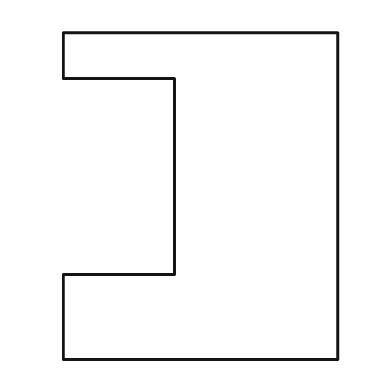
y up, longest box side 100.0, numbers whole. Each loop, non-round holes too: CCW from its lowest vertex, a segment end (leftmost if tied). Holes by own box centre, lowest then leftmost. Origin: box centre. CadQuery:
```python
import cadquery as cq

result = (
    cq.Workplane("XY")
    .moveTo(-42.0, -50.0)
    .lineTo(42.0, -50.0)
    .lineTo(42.0, 50.0)
    .lineTo(-42.0, 50.0)
    .lineTo(-42.0, 36.0)
    .lineTo(-8.0, 36.0)
    .lineTo(-8.0, -24.0)
    .lineTo(-42.0, -24.0)
    .close()
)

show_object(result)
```